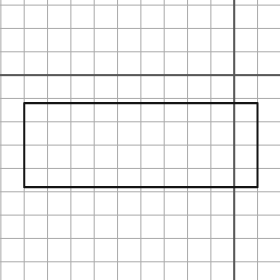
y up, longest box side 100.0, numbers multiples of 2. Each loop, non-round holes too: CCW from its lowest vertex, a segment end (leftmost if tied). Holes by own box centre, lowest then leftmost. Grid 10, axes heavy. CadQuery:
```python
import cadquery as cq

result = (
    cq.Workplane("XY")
    .moveTo(-90.0, -48.0)
    .lineTo(10.0, -48.0)
    .lineTo(10.0, -12.0)
    .lineTo(-90.0, -12.0)
    .close()
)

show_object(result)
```